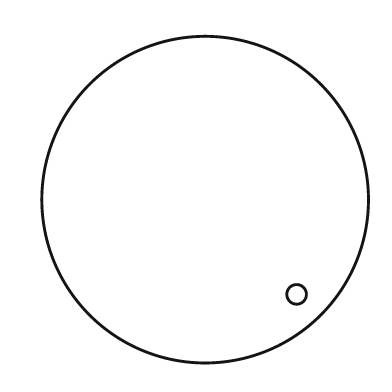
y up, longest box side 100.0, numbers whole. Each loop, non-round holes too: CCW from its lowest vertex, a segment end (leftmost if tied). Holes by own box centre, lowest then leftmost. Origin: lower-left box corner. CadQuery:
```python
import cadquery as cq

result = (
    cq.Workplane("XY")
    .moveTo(50.0, 50.0)
    .circle(50.0)
    .moveTo(78.0, 21.0)
    .circle(3.0)
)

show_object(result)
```